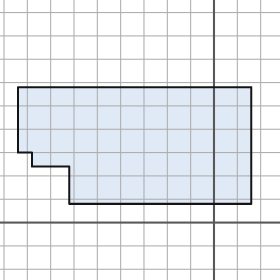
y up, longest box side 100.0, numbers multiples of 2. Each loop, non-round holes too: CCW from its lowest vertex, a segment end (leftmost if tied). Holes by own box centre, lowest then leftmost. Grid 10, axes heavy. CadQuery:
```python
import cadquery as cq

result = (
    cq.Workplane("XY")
    .moveTo(-62.0, 8.0)
    .lineTo(16.0, 8.0)
    .lineTo(16.0, 58.0)
    .lineTo(-84.0, 58.0)
    .lineTo(-84.0, 30.0)
    .lineTo(-78.0, 30.0)
    .lineTo(-78.0, 24.0)
    .lineTo(-62.0, 24.0)
    .close()
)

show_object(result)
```